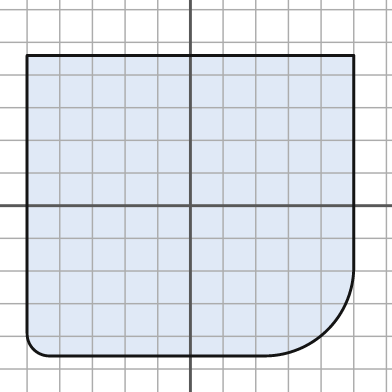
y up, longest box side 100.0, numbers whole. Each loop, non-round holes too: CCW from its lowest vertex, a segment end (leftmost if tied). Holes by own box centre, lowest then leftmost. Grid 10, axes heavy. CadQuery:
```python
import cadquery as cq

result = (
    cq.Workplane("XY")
    .moveTo(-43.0, -46.0)
    .lineTo(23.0, -46.0)
    .threePointArc((42.0, -38.0), (50.0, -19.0))
    .lineTo(50.0, 46.0)
    .lineTo(-50.0, 46.0)
    .lineTo(-50.0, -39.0)
    .threePointArc((-48.0, -44.0), (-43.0, -46.0))
    .close()
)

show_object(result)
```